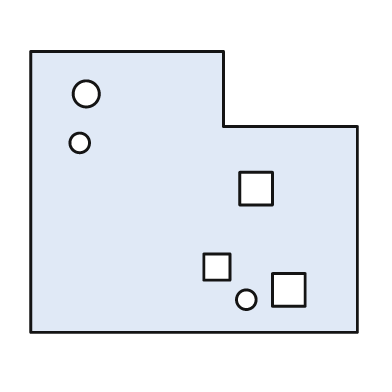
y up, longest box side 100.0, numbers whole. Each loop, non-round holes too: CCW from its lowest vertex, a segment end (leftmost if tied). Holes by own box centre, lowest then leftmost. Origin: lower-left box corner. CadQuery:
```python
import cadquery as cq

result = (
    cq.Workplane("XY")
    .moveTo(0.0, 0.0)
    .lineTo(100.0, 0.0)
    .lineTo(100.0, 63.0)
    .lineTo(59.0, 63.0)
    .lineTo(59.0, 86.0)
    .lineTo(0.0, 86.0)
    .close()
    .moveTo(66.0, 10.0)
    .circle(3.0)
    .moveTo(74.0, 8.0)
    .lineTo(84.0, 8.0)
    .lineTo(84.0, 18.0)
    .lineTo(74.0, 18.0)
    .close()
    .moveTo(53.0, 16.0)
    .lineTo(61.0, 16.0)
    .lineTo(61.0, 24.0)
    .lineTo(53.0, 24.0)
    .close()
    .moveTo(64.0, 39.0)
    .lineTo(74.0, 39.0)
    .lineTo(74.0, 49.0)
    .lineTo(64.0, 49.0)
    .close()
    .moveTo(15.0, 58.0)
    .circle(3.0)
    .moveTo(17.0, 73.0)
    .circle(4.0)
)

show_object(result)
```